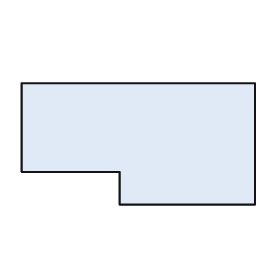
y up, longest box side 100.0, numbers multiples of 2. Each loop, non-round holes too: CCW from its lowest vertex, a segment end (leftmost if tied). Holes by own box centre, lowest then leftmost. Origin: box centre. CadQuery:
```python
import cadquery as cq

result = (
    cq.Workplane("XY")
    .moveTo(-8.0, -26.0)
    .lineTo(50.0, -26.0)
    .lineTo(50.0, 26.0)
    .lineTo(-50.0, 26.0)
    .lineTo(-50.0, -12.0)
    .lineTo(-8.0, -12.0)
    .close()
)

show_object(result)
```